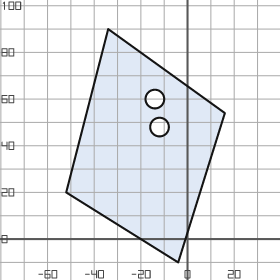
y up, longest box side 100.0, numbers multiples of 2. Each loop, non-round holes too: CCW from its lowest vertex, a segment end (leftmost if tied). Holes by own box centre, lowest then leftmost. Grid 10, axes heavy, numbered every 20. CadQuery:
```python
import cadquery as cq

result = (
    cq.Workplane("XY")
    .moveTo(-4.0, -10.0)
    .lineTo(16.0, 54.0)
    .lineTo(-34.0, 90.0)
    .lineTo(-52.0, 20.0)
    .close()
    .moveTo(-12.0, 48.0)
    .circle(4.0)
    .moveTo(-14.0, 60.0)
    .circle(4.0)
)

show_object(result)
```